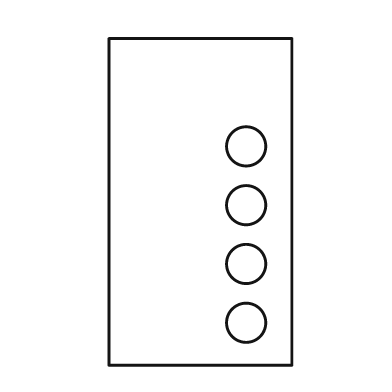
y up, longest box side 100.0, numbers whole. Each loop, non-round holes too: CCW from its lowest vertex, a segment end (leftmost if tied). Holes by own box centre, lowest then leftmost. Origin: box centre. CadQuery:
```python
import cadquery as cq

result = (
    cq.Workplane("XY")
    .moveTo(-28.0, -50.0)
    .lineTo(28.0, -50.0)
    .lineTo(28.0, 50.0)
    .lineTo(-28.0, 50.0)
    .close()
    .moveTo(14.0, -37.0)
    .circle(6.0)
    .moveTo(14.0, -19.0)
    .circle(6.0)
    .moveTo(14.0, -1.0)
    .circle(6.0)
    .moveTo(14.0, 17.0)
    .circle(6.0)
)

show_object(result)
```